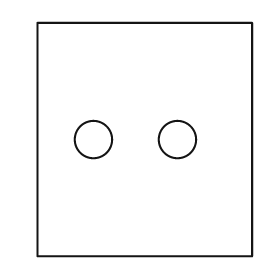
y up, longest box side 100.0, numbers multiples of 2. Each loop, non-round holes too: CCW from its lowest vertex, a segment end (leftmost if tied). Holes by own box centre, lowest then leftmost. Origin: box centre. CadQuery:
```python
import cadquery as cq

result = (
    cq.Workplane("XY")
    .moveTo(-46.0, -50.0)
    .lineTo(46.0, -50.0)
    .lineTo(46.0, 50.0)
    .lineTo(-46.0, 50.0)
    .close()
    .moveTo(-22.0, 0.0)
    .circle(8.0)
    .moveTo(14.0, 0.0)
    .circle(8.0)
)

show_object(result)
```